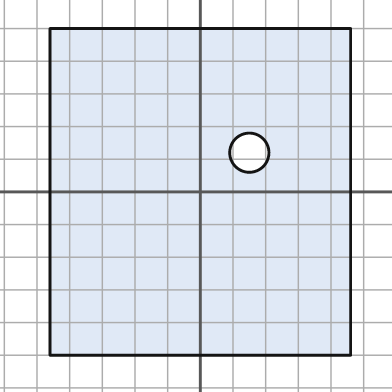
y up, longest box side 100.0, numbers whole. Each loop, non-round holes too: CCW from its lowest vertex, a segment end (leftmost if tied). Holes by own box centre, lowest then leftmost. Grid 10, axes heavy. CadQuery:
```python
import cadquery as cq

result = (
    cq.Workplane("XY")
    .moveTo(-46.0, -50.0)
    .lineTo(46.0, -50.0)
    .lineTo(46.0, 50.0)
    .lineTo(-46.0, 50.0)
    .close()
    .moveTo(15.0, 12.0)
    .circle(6.0)
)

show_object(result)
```